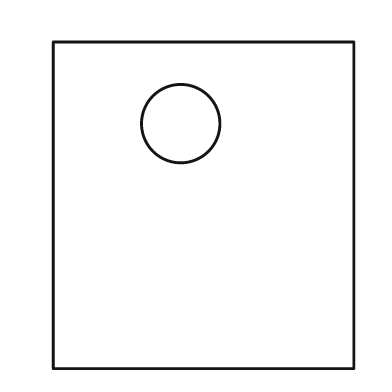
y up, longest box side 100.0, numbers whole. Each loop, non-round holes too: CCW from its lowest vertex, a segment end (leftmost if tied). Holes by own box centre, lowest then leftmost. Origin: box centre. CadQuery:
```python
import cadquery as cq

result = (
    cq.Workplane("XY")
    .moveTo(-46.0, -50.0)
    .lineTo(46.0, -50.0)
    .lineTo(46.0, 50.0)
    .lineTo(-46.0, 50.0)
    .close()
    .moveTo(-7.0, 25.0)
    .circle(12.0)
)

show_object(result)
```